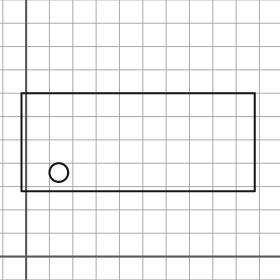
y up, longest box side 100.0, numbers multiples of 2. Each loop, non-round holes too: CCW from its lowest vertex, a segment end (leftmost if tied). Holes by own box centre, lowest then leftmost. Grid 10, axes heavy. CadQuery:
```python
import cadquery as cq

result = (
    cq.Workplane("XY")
    .moveTo(-2.0, 28.0)
    .lineTo(98.0, 28.0)
    .lineTo(98.0, 70.0)
    .lineTo(-2.0, 70.0)
    .close()
    .moveTo(14.0, 36.0)
    .circle(4.0)
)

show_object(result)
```